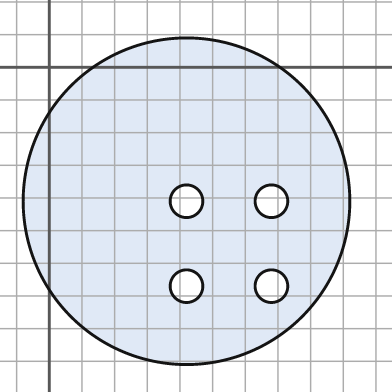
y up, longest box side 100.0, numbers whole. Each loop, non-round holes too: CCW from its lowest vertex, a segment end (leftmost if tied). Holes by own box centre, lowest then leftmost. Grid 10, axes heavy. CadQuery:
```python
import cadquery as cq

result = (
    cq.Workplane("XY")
    .moveTo(42.0, -41.0)
    .circle(50.0)
    .moveTo(42.0, -67.0)
    .circle(5.0)
    .moveTo(68.0, -67.0)
    .circle(5.0)
    .moveTo(42.0, -41.0)
    .circle(5.0)
    .moveTo(68.0, -41.0)
    .circle(5.0)
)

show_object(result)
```